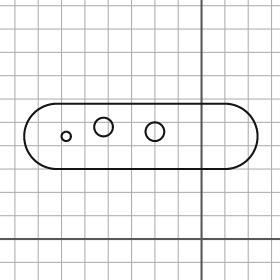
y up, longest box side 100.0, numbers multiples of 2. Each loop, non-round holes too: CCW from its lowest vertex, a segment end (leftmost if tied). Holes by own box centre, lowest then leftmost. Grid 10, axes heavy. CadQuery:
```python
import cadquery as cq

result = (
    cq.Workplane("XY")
    .moveTo(-62.0, 30.0)
    .lineTo(10.0, 30.0)
    .threePointArc((24.0, 44.0), (10.0, 58.0))
    .lineTo(-62.0, 58.0)
    .threePointArc((-76.0, 44.0), (-62.0, 30.0))
    .close()
    .moveTo(-58.0, 44.0)
    .circle(2.0)
    .moveTo(-20.0, 46.0)
    .circle(4.0)
    .moveTo(-42.0, 48.0)
    .circle(4.0)
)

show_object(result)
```